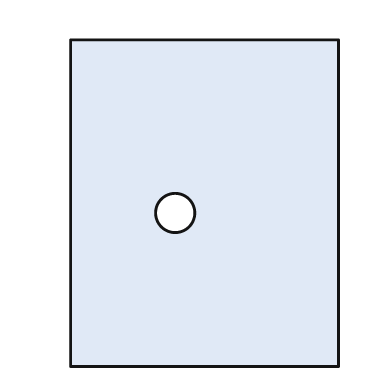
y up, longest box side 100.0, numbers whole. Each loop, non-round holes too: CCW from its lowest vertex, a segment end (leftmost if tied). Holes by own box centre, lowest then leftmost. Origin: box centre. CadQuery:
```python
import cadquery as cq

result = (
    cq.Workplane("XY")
    .moveTo(-41.0, -50.0)
    .lineTo(41.0, -50.0)
    .lineTo(41.0, 50.0)
    .lineTo(-41.0, 50.0)
    .close()
    .moveTo(-9.0, -3.0)
    .circle(6.0)
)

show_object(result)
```